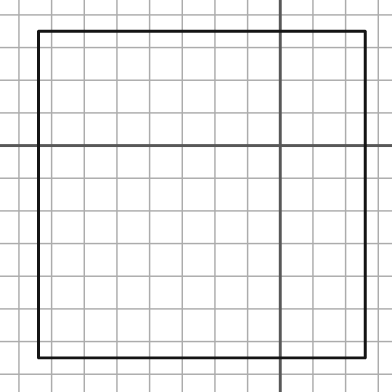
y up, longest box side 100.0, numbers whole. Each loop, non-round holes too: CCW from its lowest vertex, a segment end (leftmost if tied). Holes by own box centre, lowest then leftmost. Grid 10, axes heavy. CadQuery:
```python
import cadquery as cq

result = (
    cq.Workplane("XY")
    .moveTo(-74.0, -65.0)
    .lineTo(26.0, -65.0)
    .lineTo(26.0, 35.0)
    .lineTo(-74.0, 35.0)
    .close()
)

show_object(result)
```